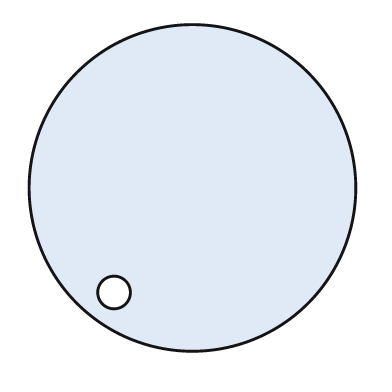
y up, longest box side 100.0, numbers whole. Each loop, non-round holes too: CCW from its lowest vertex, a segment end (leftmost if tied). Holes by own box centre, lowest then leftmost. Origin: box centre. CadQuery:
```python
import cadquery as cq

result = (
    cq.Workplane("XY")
    .moveTo(0.0, 0.0)
    .circle(50.0)
    .moveTo(-24.0, -32.0)
    .circle(5.0)
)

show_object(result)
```